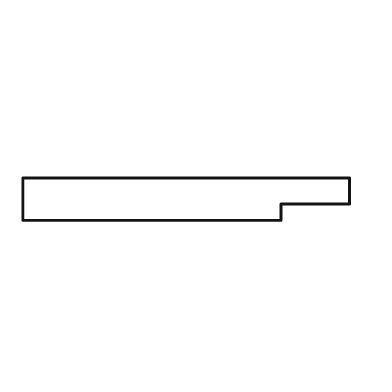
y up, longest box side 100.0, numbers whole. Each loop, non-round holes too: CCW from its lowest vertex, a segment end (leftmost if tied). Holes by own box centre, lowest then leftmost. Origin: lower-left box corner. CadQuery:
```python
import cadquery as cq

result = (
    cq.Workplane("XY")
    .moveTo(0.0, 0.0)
    .lineTo(79.0, 0.0)
    .lineTo(79.0, 5.0)
    .lineTo(100.0, 5.0)
    .lineTo(100.0, 13.0)
    .lineTo(0.0, 13.0)
    .close()
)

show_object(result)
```